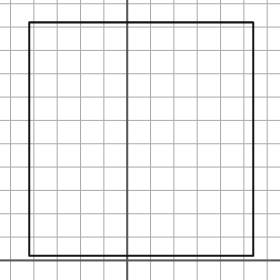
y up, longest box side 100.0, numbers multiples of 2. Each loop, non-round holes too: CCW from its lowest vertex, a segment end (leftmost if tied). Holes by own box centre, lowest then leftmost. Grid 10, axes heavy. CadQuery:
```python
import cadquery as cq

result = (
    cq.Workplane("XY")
    .moveTo(-42.0, 2.0)
    .lineTo(54.0, 2.0)
    .lineTo(54.0, 102.0)
    .lineTo(-42.0, 102.0)
    .close()
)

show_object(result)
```